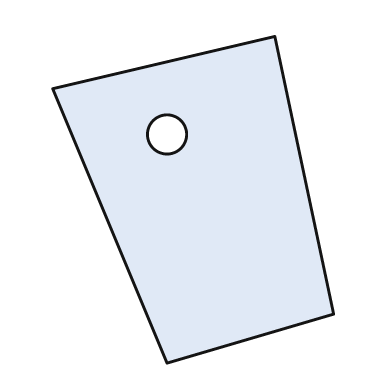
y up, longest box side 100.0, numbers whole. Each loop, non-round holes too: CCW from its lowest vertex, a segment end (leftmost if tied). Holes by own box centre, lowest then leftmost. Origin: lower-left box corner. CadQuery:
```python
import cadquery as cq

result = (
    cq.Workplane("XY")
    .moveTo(35.0, 0.0)
    .lineTo(86.0, 15.0)
    .lineTo(68.0, 100.0)
    .lineTo(0.0, 84.0)
    .close()
    .moveTo(35.0, 70.0)
    .circle(6.0)
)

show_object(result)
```